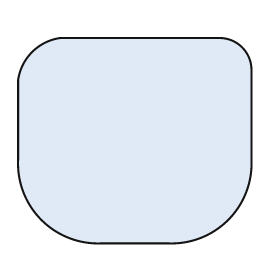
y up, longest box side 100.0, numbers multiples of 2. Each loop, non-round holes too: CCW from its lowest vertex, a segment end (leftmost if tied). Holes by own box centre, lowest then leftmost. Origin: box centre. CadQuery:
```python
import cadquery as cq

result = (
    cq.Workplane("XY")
    .moveTo(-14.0, -44.0)
    .lineTo(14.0, -44.0)
    .threePointArc((40.0, -34.0), (50.0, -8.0))
    .lineTo(50.0, 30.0)
    .threePointArc((46.0, 40.0), (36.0, 44.0))
    .lineTo(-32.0, 44.0)
    .threePointArc((-44.0, 38.0), (-50.0, 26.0))
    .lineTo(-50.0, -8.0)
    .threePointArc((-40.0, -34.0), (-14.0, -44.0))
    .close()
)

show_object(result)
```